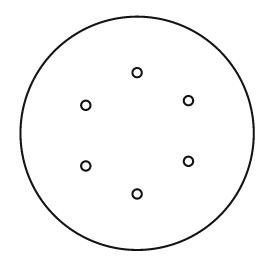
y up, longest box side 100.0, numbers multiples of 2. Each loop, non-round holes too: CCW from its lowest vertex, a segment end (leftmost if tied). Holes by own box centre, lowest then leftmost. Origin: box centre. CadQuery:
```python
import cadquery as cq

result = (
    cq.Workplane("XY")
    .moveTo(0.0, 0.0)
    .circle(50.0)
    .moveTo(0.0, -26.0)
    .circle(2.0)
    .moveTo(-22.0, -14.0)
    .circle(2.0)
    .moveTo(22.0, -12.0)
    .circle(2.0)
    .moveTo(-22.0, 12.0)
    .circle(2.0)
    .moveTo(22.0, 14.0)
    .circle(2.0)
    .moveTo(0.0, 26.0)
    .circle(2.0)
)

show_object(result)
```